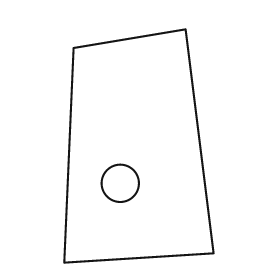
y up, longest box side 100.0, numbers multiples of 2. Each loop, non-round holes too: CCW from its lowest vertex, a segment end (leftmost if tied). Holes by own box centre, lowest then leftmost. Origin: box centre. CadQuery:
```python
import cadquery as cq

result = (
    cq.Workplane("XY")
    .moveTo(-32.0, -50.0)
    .lineTo(32.0, -46.0)
    .lineTo(20.0, 50.0)
    .lineTo(-28.0, 42.0)
    .close()
    .moveTo(-8.0, -16.0)
    .circle(8.0)
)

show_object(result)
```